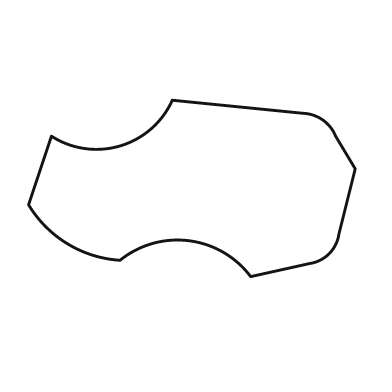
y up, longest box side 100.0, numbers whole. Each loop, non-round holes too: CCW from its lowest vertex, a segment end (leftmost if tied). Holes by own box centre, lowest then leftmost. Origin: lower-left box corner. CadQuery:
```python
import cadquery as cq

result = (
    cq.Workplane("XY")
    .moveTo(68.0, 0.0)
    .lineTo(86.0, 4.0)
    .threePointArc((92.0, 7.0), (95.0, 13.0))
    .lineTo(100.0, 33.0)
    .lineTo(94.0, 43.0)
    .threePointArc((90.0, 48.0), (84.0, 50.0))
    .lineTo(44.0, 54.0)
    .threePointArc((28.0, 40.0), (7.0, 43.0))
    .lineTo(0.0, 22.0)
    .threePointArc((12.0, 10.0), (28.0, 5.0))
    .threePointArc((49.0, 11.0), (68.0, 0.0))
    .close()
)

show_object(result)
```